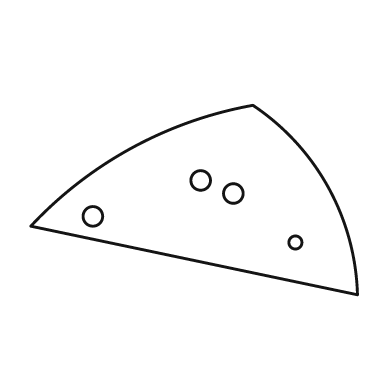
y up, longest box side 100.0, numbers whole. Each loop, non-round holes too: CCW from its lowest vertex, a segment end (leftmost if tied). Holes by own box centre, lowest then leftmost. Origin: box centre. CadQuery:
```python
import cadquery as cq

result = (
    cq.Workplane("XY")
    .moveTo(50.0, -29.0)
    .threePointArc((41.0, 4.0), (18.0, 29.0))
    .threePointArc((-19.0, 16.0), (-50.0, -8.0))
    .close()
    .moveTo(31.0, -13.0)
    .circle(2.0)
    .moveTo(-31.0, -5.0)
    .circle(3.0)
    .moveTo(12.0, 2.0)
    .circle(3.0)
    .moveTo(2.0, 6.0)
    .circle(3.0)
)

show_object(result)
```